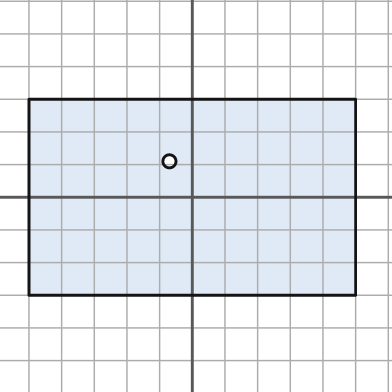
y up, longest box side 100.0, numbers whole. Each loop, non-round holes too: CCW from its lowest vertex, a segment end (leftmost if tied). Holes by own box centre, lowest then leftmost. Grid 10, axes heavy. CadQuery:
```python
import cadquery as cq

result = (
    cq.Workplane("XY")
    .moveTo(-50.0, -30.0)
    .lineTo(50.0, -30.0)
    .lineTo(50.0, 30.0)
    .lineTo(-50.0, 30.0)
    .close()
    .moveTo(-7.0, 11.0)
    .circle(2.0)
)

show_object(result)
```